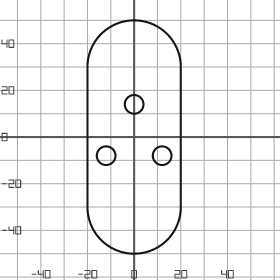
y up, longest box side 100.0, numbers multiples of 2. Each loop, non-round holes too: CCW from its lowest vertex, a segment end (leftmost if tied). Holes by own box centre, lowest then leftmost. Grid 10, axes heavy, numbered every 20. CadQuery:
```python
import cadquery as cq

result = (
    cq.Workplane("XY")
    .moveTo(-20.0, -30.0)
    .threePointArc((0.0, -50.0), (20.0, -30.0))
    .lineTo(20.0, 30.0)
    .threePointArc((0.0, 50.0), (-20.0, 30.0))
    .close()
    .moveTo(-12.0, -8.0)
    .circle(4.0)
    .moveTo(12.0, -8.0)
    .circle(4.0)
    .moveTo(0.0, 14.0)
    .circle(4.0)
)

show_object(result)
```